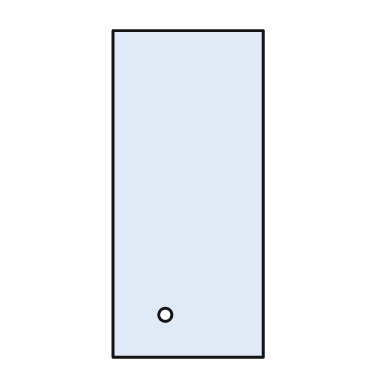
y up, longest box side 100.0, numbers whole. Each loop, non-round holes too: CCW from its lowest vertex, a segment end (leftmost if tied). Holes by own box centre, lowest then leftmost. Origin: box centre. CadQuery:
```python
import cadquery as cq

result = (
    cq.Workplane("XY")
    .moveTo(-23.0, -50.0)
    .lineTo(23.0, -50.0)
    .lineTo(23.0, 50.0)
    .lineTo(-23.0, 50.0)
    .close()
    .moveTo(-7.0, -37.0)
    .circle(2.0)
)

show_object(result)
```